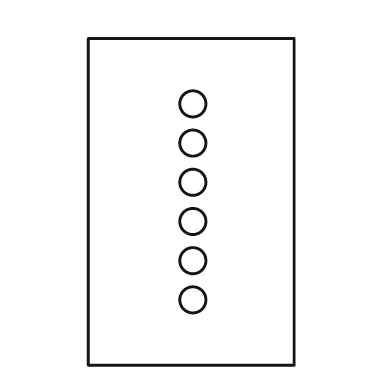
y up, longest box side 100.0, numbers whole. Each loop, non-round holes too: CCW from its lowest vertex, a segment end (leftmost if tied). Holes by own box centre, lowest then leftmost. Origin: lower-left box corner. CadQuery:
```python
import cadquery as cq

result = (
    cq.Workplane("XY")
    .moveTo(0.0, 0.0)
    .lineTo(63.0, 0.0)
    .lineTo(63.0, 100.0)
    .lineTo(0.0, 100.0)
    .close()
    .moveTo(32.0, 20.0)
    .circle(4.0)
    .moveTo(32.0, 32.0)
    .circle(4.0)
    .moveTo(32.0, 44.0)
    .circle(4.0)
    .moveTo(32.0, 56.0)
    .circle(4.0)
    .moveTo(32.0, 68.0)
    .circle(4.0)
    .moveTo(32.0, 80.0)
    .circle(4.0)
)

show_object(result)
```